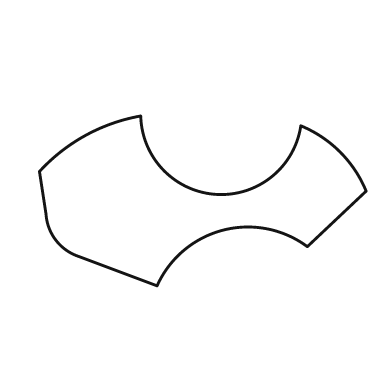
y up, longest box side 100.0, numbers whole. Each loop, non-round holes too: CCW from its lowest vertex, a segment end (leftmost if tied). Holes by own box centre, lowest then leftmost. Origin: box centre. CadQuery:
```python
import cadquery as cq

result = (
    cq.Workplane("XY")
    .moveTo(-14.0, -26.0)
    .threePointArc((6.0, -9.0), (32.0, -14.0))
    .lineTo(50.0, 3.0)
    .threePointArc((42.0, 15.0), (30.0, 23.0))
    .threePointArc((4.0, 2.0), (-19.0, 26.0))
    .threePointArc((-36.0, 20.0), (-50.0, 9.0))
    .lineTo(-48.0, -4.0)
    .threePointArc((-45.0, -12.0), (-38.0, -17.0))
    .close()
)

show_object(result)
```